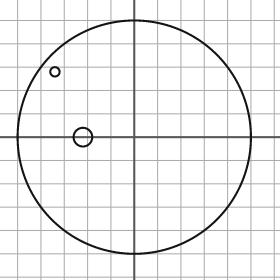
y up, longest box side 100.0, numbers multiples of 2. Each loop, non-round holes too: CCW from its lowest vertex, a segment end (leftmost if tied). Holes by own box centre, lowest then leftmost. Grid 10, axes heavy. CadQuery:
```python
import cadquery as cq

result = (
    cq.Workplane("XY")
    .moveTo(0.0, 0.0)
    .circle(50.0)
    .moveTo(-22.0, 0.0)
    .circle(4.0)
    .moveTo(-34.0, 28.0)
    .circle(2.0)
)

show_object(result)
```